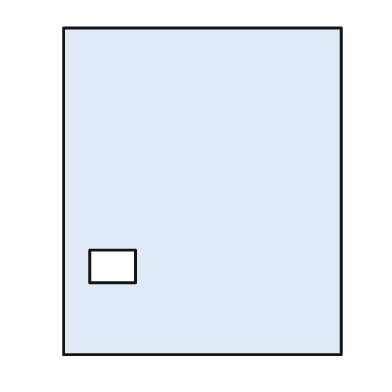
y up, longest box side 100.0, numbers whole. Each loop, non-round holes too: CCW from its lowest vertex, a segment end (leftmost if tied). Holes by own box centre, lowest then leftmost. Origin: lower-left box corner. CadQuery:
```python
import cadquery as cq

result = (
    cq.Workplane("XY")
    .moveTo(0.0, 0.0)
    .lineTo(85.0, 0.0)
    .lineTo(85.0, 100.0)
    .lineTo(0.0, 100.0)
    .close()
    .moveTo(8.0, 22.0)
    .lineTo(22.0, 22.0)
    .lineTo(22.0, 32.0)
    .lineTo(8.0, 32.0)
    .close()
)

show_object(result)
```